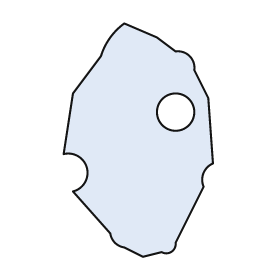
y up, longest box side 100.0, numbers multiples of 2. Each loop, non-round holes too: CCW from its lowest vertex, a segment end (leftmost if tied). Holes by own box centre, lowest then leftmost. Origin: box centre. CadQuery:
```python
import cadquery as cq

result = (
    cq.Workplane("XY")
    .moveTo(2.0, -50.0)
    .lineTo(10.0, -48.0)
    .threePointArc((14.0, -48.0), (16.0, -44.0))
    .lineTo(28.0, -20.0)
    .threePointArc((28.0, -14.0), (32.0, -10.0))
    .lineTo(30.0, 18.0)
    .lineTo(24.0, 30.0)
    .threePointArc((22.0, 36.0), (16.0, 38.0))
    .lineTo(8.0, 44.0)
    .lineTo(-6.0, 50.0)
    .threePointArc((-12.0, 44.0), (-16.0, 36.0))
    .lineTo(-28.0, 20.0)
    .lineTo(-32.0, -6.0)
    .threePointArc((-22.0, -12.0), (-28.0, -22.0))
    .lineTo(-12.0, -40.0)
    .threePointArc((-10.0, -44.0), (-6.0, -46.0))
    .close()
    .moveTo(16.0, 12.0)
    .circle(8.0)
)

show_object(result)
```